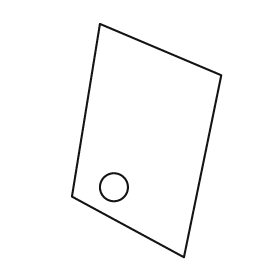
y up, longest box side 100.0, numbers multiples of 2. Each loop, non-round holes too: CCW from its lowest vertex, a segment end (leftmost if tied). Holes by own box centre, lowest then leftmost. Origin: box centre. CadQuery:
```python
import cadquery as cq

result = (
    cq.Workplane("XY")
    .moveTo(16.0, -50.0)
    .lineTo(32.0, 28.0)
    .lineTo(-20.0, 50.0)
    .lineTo(-32.0, -24.0)
    .close()
    .moveTo(-14.0, -20.0)
    .circle(6.0)
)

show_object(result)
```